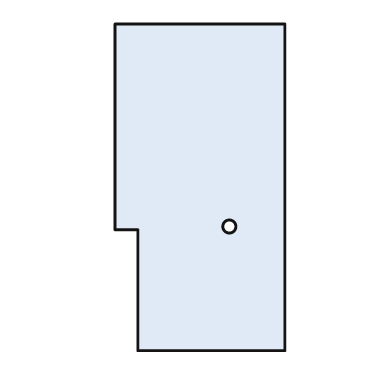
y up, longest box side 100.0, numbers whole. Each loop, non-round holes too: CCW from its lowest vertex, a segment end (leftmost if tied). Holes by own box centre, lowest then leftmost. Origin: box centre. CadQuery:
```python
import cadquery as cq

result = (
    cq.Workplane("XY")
    .moveTo(-19.0, -50.0)
    .lineTo(26.0, -50.0)
    .lineTo(26.0, 50.0)
    .lineTo(-26.0, 50.0)
    .lineTo(-26.0, -13.0)
    .lineTo(-19.0, -13.0)
    .close()
    .moveTo(9.0, -12.0)
    .circle(2.0)
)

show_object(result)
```